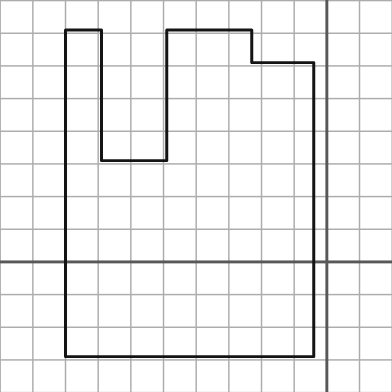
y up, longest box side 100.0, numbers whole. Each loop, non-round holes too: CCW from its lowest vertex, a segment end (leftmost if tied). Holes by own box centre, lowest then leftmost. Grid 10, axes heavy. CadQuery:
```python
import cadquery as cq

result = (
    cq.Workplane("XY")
    .moveTo(-80.0, -29.0)
    .lineTo(-4.0, -29.0)
    .lineTo(-4.0, 61.0)
    .lineTo(-23.0, 61.0)
    .lineTo(-23.0, 71.0)
    .lineTo(-49.0, 71.0)
    .lineTo(-49.0, 31.0)
    .lineTo(-69.0, 31.0)
    .lineTo(-69.0, 71.0)
    .lineTo(-80.0, 71.0)
    .close()
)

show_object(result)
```